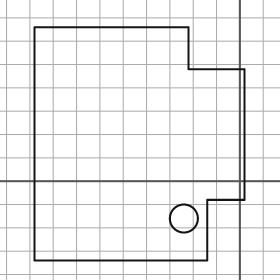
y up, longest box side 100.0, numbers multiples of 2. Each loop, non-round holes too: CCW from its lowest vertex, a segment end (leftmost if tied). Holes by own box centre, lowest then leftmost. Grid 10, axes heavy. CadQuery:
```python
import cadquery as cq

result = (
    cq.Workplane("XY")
    .moveTo(-88.0, -34.0)
    .lineTo(-14.0, -34.0)
    .lineTo(-14.0, -8.0)
    .lineTo(2.0, -8.0)
    .lineTo(2.0, 48.0)
    .lineTo(-22.0, 48.0)
    .lineTo(-22.0, 66.0)
    .lineTo(-88.0, 66.0)
    .close()
    .moveTo(-24.0, -16.0)
    .circle(6.0)
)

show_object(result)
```